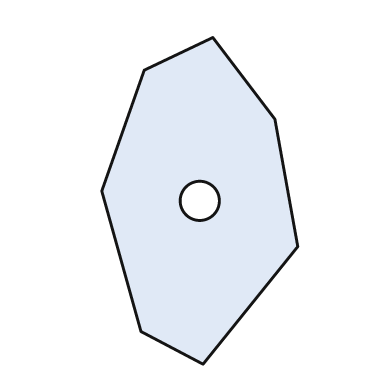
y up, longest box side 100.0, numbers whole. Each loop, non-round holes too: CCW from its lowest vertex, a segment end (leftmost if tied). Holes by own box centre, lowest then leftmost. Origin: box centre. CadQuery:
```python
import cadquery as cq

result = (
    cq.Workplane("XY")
    .moveTo(1.0, -50.0)
    .lineTo(30.0, -14.0)
    .lineTo(23.0, 25.0)
    .lineTo(4.0, 50.0)
    .lineTo(-17.0, 40.0)
    .lineTo(-30.0, 3.0)
    .lineTo(-18.0, -40.0)
    .close()
    .moveTo(0.0, 0.0)
    .circle(6.0)
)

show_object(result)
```